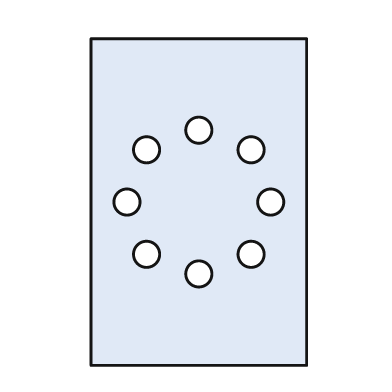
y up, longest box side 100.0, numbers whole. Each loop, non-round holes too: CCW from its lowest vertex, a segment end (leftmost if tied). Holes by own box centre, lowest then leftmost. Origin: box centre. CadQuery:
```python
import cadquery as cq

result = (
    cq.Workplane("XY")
    .moveTo(-33.0, -50.0)
    .lineTo(33.0, -50.0)
    .lineTo(33.0, 50.0)
    .lineTo(-33.0, 50.0)
    .close()
    .moveTo(0.0, -22.0)
    .circle(4.0)
    .moveTo(-16.0, -16.0)
    .circle(4.0)
    .moveTo(16.0, -16.0)
    .circle(4.0)
    .moveTo(-22.0, 0.0)
    .circle(4.0)
    .moveTo(22.0, 0.0)
    .circle(4.0)
    .moveTo(-16.0, 16.0)
    .circle(4.0)
    .moveTo(16.0, 16.0)
    .circle(4.0)
    .moveTo(0.0, 22.0)
    .circle(4.0)
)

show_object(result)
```